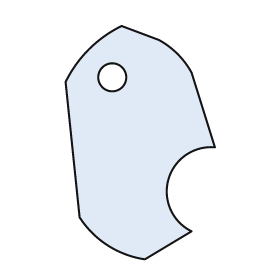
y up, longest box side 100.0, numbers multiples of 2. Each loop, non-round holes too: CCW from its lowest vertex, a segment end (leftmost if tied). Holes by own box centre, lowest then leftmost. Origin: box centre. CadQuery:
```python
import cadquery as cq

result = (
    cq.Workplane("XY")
    .moveTo(2.0, -50.0)
    .lineTo(22.0, -38.0)
    .threePointArc((12.0, -16.0), (32.0, -2.0))
    .lineTo(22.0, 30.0)
    .threePointArc((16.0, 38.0), (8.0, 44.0))
    .lineTo(-8.0, 50.0)
    .threePointArc((-22.0, 40.0), (-32.0, 26.0))
    .lineTo(-26.0, -32.0)
    .threePointArc((-14.0, -44.0), (2.0, -50.0))
    .close()
    .moveTo(-12.0, 28.0)
    .circle(6.0)
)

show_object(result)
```